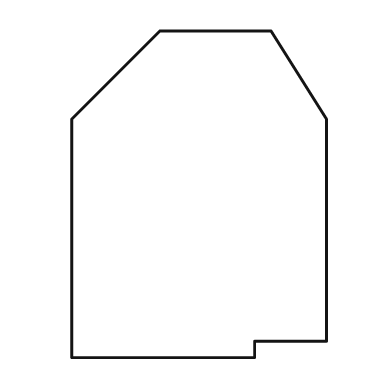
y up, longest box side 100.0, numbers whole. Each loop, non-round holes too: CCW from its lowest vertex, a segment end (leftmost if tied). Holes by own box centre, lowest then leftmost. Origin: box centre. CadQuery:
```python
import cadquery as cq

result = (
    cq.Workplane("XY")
    .moveTo(-39.0, -50.0)
    .lineTo(17.0, -50.0)
    .lineTo(17.0, -45.0)
    .lineTo(39.0, -45.0)
    .lineTo(39.0, 23.0)
    .lineTo(22.0, 50.0)
    .lineTo(-12.0, 50.0)
    .lineTo(-39.0, 23.0)
    .close()
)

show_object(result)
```